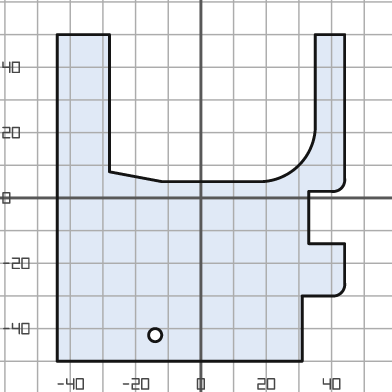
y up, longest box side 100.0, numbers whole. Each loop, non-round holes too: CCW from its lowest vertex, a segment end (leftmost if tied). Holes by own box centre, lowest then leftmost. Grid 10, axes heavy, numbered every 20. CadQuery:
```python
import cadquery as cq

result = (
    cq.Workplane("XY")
    .moveTo(-44.0, -50.0)
    .lineTo(31.0, -50.0)
    .lineTo(31.0, -30.0)
    .lineTo(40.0, -30.0)
    .threePointArc((43.0, -29.0), (44.0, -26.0))
    .lineTo(44.0, -14.0)
    .lineTo(33.0, -14.0)
    .lineTo(33.0, 2.0)
    .lineTo(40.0, 2.0)
    .threePointArc((43.0, 3.0), (44.0, 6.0))
    .lineTo(44.0, 50.0)
    .lineTo(35.0, 50.0)
    .lineTo(35.0, 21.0)
    .threePointArc((30.0, 10.0), (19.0, 5.0))
    .lineTo(-12.0, 5.0)
    .lineTo(-28.0, 8.0)
    .lineTo(-28.0, 50.0)
    .lineTo(-44.0, 50.0)
    .close()
    .moveTo(-14.0, -42.0)
    .circle(2.0)
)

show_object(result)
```